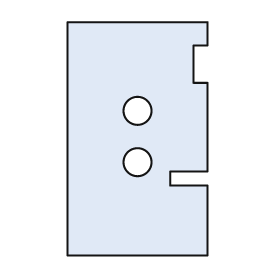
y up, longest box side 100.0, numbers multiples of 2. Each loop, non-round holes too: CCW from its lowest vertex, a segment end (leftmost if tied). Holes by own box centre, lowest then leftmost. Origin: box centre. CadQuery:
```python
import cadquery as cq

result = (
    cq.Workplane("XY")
    .moveTo(-30.0, -50.0)
    .lineTo(30.0, -50.0)
    .lineTo(30.0, -20.0)
    .lineTo(14.0, -20.0)
    .lineTo(14.0, -14.0)
    .lineTo(30.0, -14.0)
    .lineTo(30.0, 24.0)
    .lineTo(24.0, 24.0)
    .lineTo(24.0, 40.0)
    .lineTo(30.0, 40.0)
    .lineTo(30.0, 50.0)
    .lineTo(-30.0, 50.0)
    .close()
    .moveTo(0.0, -10.0)
    .circle(6.0)
    .moveTo(0.0, 12.0)
    .circle(6.0)
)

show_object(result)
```